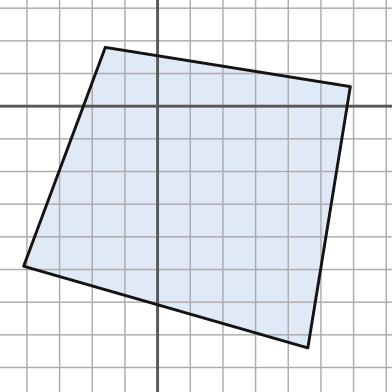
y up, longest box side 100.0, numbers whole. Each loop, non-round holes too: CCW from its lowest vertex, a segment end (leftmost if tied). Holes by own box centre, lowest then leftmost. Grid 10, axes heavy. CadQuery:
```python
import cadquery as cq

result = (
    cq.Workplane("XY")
    .moveTo(46.0, -74.0)
    .lineTo(59.0, 6.0)
    .lineTo(-16.0, 18.0)
    .lineTo(-41.0, -49.0)
    .close()
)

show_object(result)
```